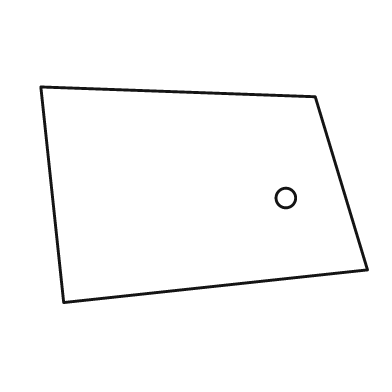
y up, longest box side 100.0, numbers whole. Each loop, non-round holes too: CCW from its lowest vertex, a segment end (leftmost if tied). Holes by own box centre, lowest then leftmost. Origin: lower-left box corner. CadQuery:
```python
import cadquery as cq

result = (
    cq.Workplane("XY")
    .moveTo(7.0, 0.0)
    .lineTo(100.0, 10.0)
    .lineTo(84.0, 63.0)
    .lineTo(0.0, 66.0)
    .close()
    .moveTo(75.0, 32.0)
    .circle(3.0)
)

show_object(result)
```